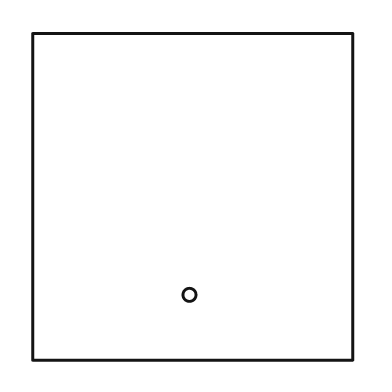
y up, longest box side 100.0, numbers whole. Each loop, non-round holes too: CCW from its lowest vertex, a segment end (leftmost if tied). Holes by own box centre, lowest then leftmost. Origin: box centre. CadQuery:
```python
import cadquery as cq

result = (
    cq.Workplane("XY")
    .moveTo(-49.0, -50.0)
    .lineTo(49.0, -50.0)
    .lineTo(49.0, 50.0)
    .lineTo(-49.0, 50.0)
    .close()
    .moveTo(-1.0, -30.0)
    .circle(2.0)
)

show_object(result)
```